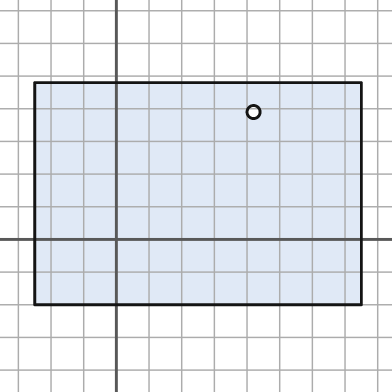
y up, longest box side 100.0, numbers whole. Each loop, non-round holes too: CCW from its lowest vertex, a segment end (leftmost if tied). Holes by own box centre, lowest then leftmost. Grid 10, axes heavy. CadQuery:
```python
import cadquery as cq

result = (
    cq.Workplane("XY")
    .moveTo(-25.0, -20.0)
    .lineTo(75.0, -20.0)
    .lineTo(75.0, 48.0)
    .lineTo(-25.0, 48.0)
    .close()
    .moveTo(42.0, 39.0)
    .circle(2.0)
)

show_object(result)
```